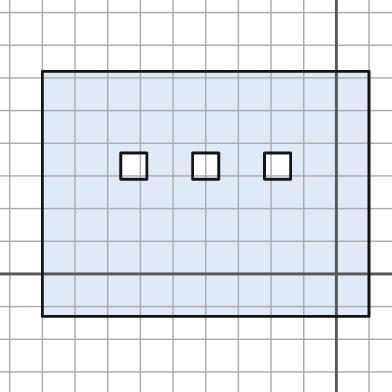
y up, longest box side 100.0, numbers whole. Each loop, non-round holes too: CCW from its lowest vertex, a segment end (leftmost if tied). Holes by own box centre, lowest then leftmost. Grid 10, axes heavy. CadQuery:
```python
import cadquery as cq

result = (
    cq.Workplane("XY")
    .moveTo(-90.0, -13.0)
    .lineTo(10.0, -13.0)
    .lineTo(10.0, 62.0)
    .lineTo(-90.0, 62.0)
    .close()
    .moveTo(-66.0, 29.0)
    .lineTo(-58.0, 29.0)
    .lineTo(-58.0, 37.0)
    .lineTo(-66.0, 37.0)
    .close()
    .moveTo(-44.0, 29.0)
    .lineTo(-36.0, 29.0)
    .lineTo(-36.0, 37.0)
    .lineTo(-44.0, 37.0)
    .close()
    .moveTo(-22.0, 29.0)
    .lineTo(-14.0, 29.0)
    .lineTo(-14.0, 37.0)
    .lineTo(-22.0, 37.0)
    .close()
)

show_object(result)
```